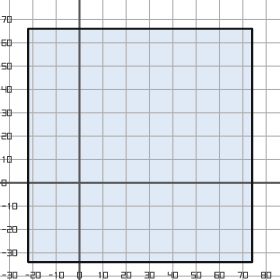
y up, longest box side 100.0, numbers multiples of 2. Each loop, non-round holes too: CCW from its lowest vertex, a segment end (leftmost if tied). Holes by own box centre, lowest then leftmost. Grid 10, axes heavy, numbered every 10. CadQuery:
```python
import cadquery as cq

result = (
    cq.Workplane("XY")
    .moveTo(-22.0, -34.0)
    .lineTo(74.0, -34.0)
    .lineTo(74.0, 66.0)
    .lineTo(-22.0, 66.0)
    .close()
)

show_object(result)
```